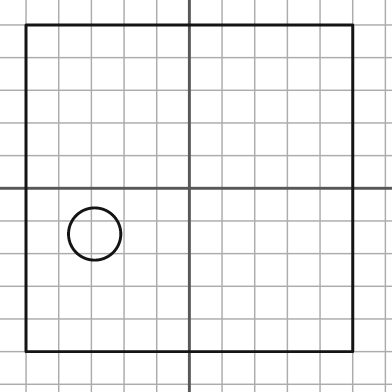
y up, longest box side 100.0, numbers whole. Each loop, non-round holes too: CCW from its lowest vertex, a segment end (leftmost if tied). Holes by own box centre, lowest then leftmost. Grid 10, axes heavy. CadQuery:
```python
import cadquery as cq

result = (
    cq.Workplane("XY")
    .moveTo(-50.0, -50.0)
    .lineTo(50.0, -50.0)
    .lineTo(50.0, 50.0)
    .lineTo(-50.0, 50.0)
    .close()
    .moveTo(-29.0, -14.0)
    .circle(8.0)
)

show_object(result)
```